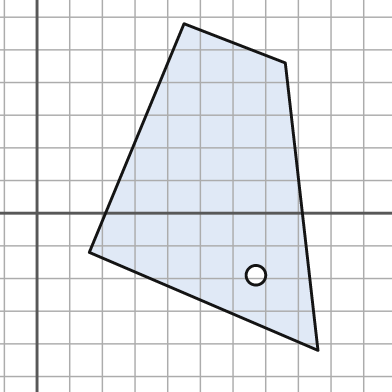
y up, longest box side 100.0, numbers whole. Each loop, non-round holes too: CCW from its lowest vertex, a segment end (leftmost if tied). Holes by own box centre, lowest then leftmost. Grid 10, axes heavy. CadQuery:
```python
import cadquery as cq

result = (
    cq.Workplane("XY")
    .moveTo(86.0, -42.0)
    .lineTo(76.0, 46.0)
    .lineTo(45.0, 58.0)
    .lineTo(16.0, -12.0)
    .close()
    .moveTo(67.0, -19.0)
    .circle(3.0)
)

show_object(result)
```